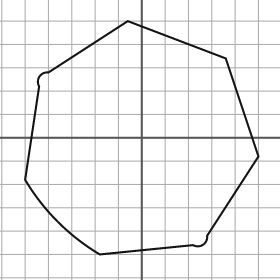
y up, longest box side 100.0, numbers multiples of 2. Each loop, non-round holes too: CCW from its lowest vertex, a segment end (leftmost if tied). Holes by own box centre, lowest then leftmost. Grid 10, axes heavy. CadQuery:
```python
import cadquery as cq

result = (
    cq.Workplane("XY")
    .moveTo(-18.0, -50.0)
    .lineTo(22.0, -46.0)
    .threePointArc((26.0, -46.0), (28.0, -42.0))
    .lineTo(50.0, -8.0)
    .lineTo(36.0, 34.0)
    .lineTo(-6.0, 50.0)
    .lineTo(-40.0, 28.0)
    .threePointArc((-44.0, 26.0), (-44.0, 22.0))
    .lineTo(-50.0, -18.0)
    .threePointArc((-36.0, -36.0), (-18.0, -50.0))
    .close()
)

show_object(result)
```